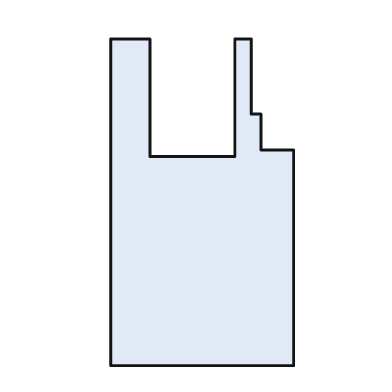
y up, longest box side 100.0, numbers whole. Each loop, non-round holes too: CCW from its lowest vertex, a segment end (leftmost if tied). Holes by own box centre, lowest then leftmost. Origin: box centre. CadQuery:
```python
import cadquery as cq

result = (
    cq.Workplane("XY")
    .moveTo(-28.0, -50.0)
    .lineTo(28.0, -50.0)
    .lineTo(28.0, 16.0)
    .lineTo(18.0, 16.0)
    .lineTo(18.0, 27.0)
    .lineTo(15.0, 27.0)
    .lineTo(15.0, 50.0)
    .lineTo(10.0, 50.0)
    .lineTo(10.0, 14.0)
    .lineTo(-16.0, 14.0)
    .lineTo(-16.0, 50.0)
    .lineTo(-28.0, 50.0)
    .close()
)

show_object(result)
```